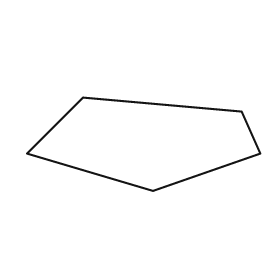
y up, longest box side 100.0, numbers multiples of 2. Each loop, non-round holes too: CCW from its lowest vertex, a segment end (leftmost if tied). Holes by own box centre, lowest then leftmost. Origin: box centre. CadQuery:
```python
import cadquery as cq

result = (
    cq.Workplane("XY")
    .moveTo(4.0, -20.0)
    .lineTo(50.0, -4.0)
    .lineTo(42.0, 14.0)
    .lineTo(-26.0, 20.0)
    .lineTo(-50.0, -4.0)
    .close()
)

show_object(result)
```